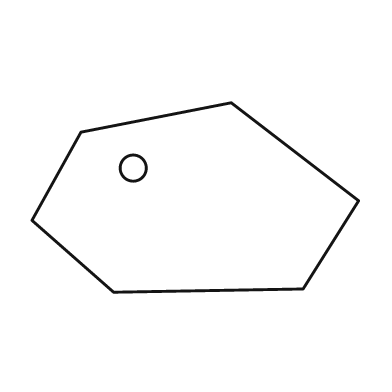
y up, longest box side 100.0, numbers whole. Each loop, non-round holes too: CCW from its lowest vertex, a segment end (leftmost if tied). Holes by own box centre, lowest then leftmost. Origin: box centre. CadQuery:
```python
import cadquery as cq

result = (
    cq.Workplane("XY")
    .moveTo(-25.0, -29.0)
    .lineTo(33.0, -28.0)
    .lineTo(50.0, -1.0)
    .lineTo(11.0, 29.0)
    .lineTo(-35.0, 20.0)
    .lineTo(-50.0, -7.0)
    .close()
    .moveTo(-19.0, 9.0)
    .circle(4.0)
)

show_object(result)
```